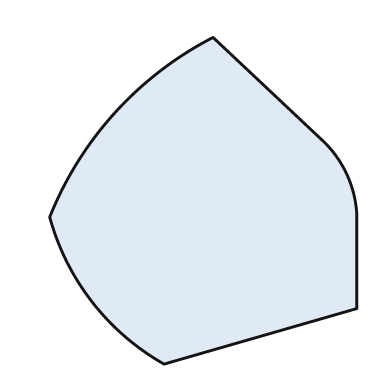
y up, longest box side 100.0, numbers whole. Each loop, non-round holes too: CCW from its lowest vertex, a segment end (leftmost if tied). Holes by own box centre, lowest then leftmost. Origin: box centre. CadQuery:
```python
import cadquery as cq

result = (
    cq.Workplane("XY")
    .moveTo(-12.0, -50.0)
    .lineTo(47.0, -33.0)
    .lineTo(47.0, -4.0)
    .threePointArc((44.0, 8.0), (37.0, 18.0))
    .lineTo(3.0, 50.0)
    .threePointArc((-27.0, 27.0), (-47.0, -5.0))
    .threePointArc((-34.0, -31.0), (-12.0, -50.0))
    .close()
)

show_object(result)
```